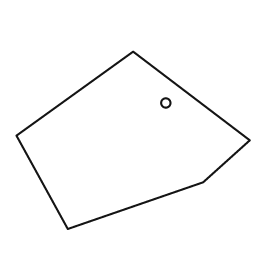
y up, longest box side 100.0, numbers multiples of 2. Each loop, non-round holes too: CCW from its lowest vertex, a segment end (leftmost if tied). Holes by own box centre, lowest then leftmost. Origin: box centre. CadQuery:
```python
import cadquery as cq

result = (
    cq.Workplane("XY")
    .moveTo(-28.0, -38.0)
    .lineTo(30.0, -18.0)
    .lineTo(50.0, 0.0)
    .lineTo(0.0, 38.0)
    .lineTo(-50.0, 2.0)
    .close()
    .moveTo(14.0, 16.0)
    .circle(2.0)
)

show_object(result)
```